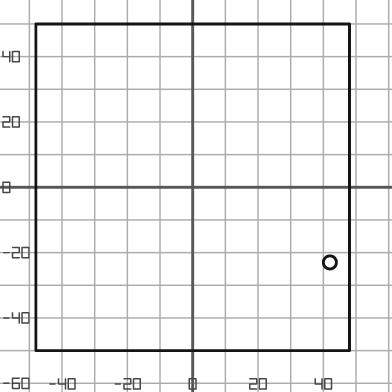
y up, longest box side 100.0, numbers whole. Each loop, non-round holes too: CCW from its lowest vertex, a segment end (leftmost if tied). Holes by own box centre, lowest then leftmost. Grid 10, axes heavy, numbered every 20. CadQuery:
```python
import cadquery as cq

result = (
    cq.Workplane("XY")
    .moveTo(-48.0, -50.0)
    .lineTo(48.0, -50.0)
    .lineTo(48.0, 50.0)
    .lineTo(-48.0, 50.0)
    .close()
    .moveTo(42.0, -23.0)
    .circle(2.0)
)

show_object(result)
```